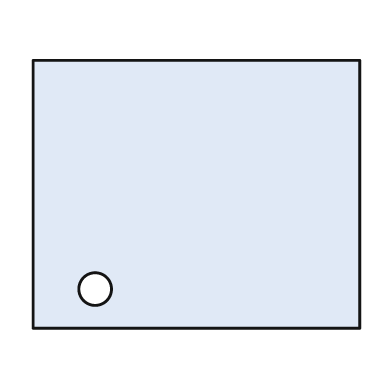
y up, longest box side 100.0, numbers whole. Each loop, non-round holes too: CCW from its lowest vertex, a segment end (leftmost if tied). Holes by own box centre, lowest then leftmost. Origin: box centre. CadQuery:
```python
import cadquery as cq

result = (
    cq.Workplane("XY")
    .moveTo(-50.0, -41.0)
    .lineTo(50.0, -41.0)
    .lineTo(50.0, 41.0)
    .lineTo(-50.0, 41.0)
    .close()
    .moveTo(-31.0, -29.0)
    .circle(5.0)
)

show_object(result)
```